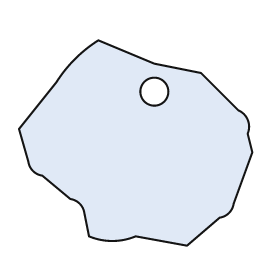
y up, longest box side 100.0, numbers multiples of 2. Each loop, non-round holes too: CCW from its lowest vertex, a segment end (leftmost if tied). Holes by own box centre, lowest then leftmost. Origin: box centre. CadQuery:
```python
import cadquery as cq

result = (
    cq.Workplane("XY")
    .moveTo(22.0, -44.0)
    .lineTo(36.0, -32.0)
    .threePointArc((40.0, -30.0), (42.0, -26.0))
    .lineTo(50.0, -4.0)
    .lineTo(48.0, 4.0)
    .threePointArc((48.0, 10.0), (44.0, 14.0))
    .lineTo(28.0, 30.0)
    .lineTo(8.0, 34.0)
    .lineTo(-16.0, 44.0)
    .threePointArc((-26.0, 36.0), (-34.0, 26.0))
    .lineTo(-50.0, 6.0)
    .lineTo(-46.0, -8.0)
    .threePointArc((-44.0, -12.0), (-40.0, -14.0))
    .lineTo(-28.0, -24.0)
    .threePointArc((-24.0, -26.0), (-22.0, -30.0))
    .lineTo(-20.0, -40.0)
    .threePointArc((-10.0, -42.0), (0.0, -40.0))
    .close()
    .moveTo(8.0, 22.0)
    .circle(6.0)
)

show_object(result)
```